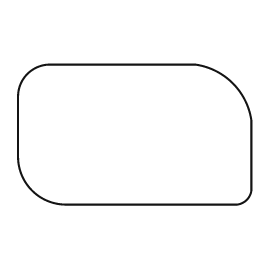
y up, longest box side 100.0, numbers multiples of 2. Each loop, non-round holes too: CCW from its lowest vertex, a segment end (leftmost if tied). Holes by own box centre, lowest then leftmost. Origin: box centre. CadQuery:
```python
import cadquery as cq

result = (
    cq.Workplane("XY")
    .moveTo(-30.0, -30.0)
    .lineTo(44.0, -30.0)
    .threePointArc((48.0, -28.0), (50.0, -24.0))
    .lineTo(50.0, 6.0)
    .threePointArc((42.0, 22.0), (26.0, 30.0))
    .lineTo(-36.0, 30.0)
    .threePointArc((-46.0, 26.0), (-50.0, 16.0))
    .lineTo(-50.0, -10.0)
    .threePointArc((-44.0, -24.0), (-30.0, -30.0))
    .close()
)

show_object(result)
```